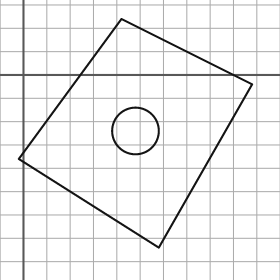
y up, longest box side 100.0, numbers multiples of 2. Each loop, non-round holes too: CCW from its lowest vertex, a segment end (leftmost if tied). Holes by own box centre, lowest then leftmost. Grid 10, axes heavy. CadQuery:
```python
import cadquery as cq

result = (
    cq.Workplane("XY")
    .moveTo(58.0, -74.0)
    .lineTo(98.0, -4.0)
    .lineTo(42.0, 24.0)
    .lineTo(-2.0, -36.0)
    .close()
    .moveTo(48.0, -24.0)
    .circle(10.0)
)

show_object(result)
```